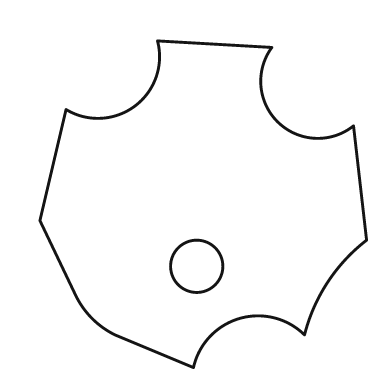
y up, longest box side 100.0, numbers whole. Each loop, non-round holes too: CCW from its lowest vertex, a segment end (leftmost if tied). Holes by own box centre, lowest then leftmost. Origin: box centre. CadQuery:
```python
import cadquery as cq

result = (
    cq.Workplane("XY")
    .moveTo(-3.0, -50.0)
    .threePointArc((11.0, -35.0), (31.0, -40.0))
    .threePointArc((38.0, -24.0), (50.0, -11.0))
    .lineTo(46.0, 24.0)
    .threePointArc((23.0, 25.0), (21.0, 48.0))
    .lineTo(-14.0, 50.0)
    .threePointArc((-21.0, 30.0), (-42.0, 29.0))
    .lineTo(-50.0, -5.0)
    .lineTo(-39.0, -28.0)
    .threePointArc((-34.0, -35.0), (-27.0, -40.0))
    .close()
    .moveTo(-2.0, -19.0)
    .circle(8.0)
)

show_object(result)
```